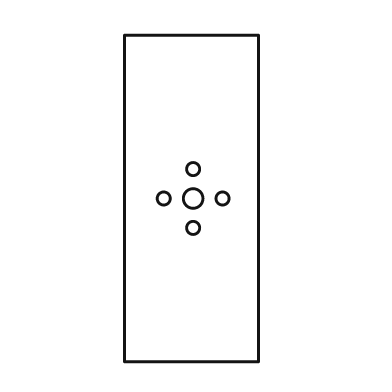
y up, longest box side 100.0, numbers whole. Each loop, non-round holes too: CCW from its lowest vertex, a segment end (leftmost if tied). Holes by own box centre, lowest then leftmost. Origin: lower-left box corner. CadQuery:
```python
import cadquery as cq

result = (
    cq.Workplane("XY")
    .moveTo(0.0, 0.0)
    .lineTo(41.0, 0.0)
    .lineTo(41.0, 100.0)
    .lineTo(0.0, 100.0)
    .close()
    .moveTo(21.0, 41.0)
    .circle(2.0)
    .moveTo(12.0, 50.0)
    .circle(2.0)
    .moveTo(21.0, 50.0)
    .circle(3.0)
    .moveTo(30.0, 50.0)
    .circle(2.0)
    .moveTo(21.0, 59.0)
    .circle(2.0)
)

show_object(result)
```